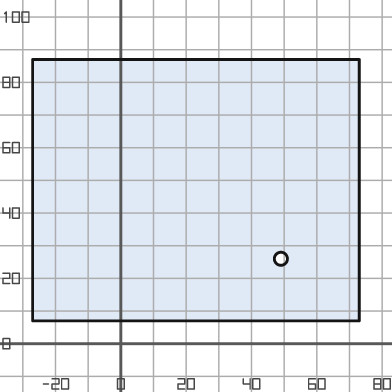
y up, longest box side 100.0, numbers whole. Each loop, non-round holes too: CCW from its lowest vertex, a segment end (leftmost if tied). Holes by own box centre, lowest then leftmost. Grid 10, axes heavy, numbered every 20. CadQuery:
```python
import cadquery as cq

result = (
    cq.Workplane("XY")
    .moveTo(-27.0, 7.0)
    .lineTo(73.0, 7.0)
    .lineTo(73.0, 87.0)
    .lineTo(-27.0, 87.0)
    .close()
    .moveTo(49.0, 26.0)
    .circle(2.0)
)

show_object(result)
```